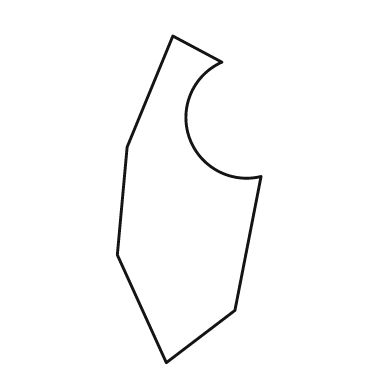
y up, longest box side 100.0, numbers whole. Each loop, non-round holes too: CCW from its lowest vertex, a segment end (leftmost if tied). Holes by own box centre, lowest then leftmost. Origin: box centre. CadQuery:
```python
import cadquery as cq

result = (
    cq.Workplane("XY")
    .moveTo(-7.0, -50.0)
    .lineTo(14.0, -34.0)
    .lineTo(22.0, 7.0)
    .threePointArc((0.0, 19.0), (10.0, 42.0))
    .lineTo(-5.0, 50.0)
    .lineTo(-19.0, 16.0)
    .lineTo(-22.0, -17.0)
    .close()
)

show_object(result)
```